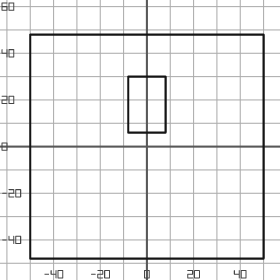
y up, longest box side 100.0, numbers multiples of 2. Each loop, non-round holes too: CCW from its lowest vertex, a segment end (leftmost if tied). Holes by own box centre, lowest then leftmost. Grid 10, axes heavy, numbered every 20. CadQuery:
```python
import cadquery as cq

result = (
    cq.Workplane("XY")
    .moveTo(-50.0, -48.0)
    .lineTo(50.0, -48.0)
    .lineTo(50.0, 48.0)
    .lineTo(-50.0, 48.0)
    .close()
    .moveTo(-8.0, 6.0)
    .lineTo(8.0, 6.0)
    .lineTo(8.0, 30.0)
    .lineTo(-8.0, 30.0)
    .close()
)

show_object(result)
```